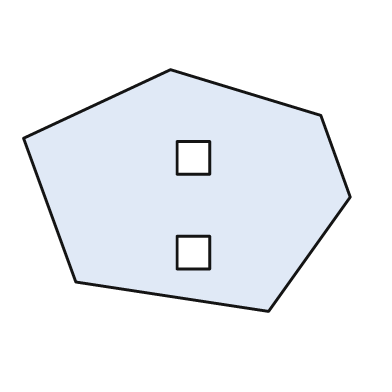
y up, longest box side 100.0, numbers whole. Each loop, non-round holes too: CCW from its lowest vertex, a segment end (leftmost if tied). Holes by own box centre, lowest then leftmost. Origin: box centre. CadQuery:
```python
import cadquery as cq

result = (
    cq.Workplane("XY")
    .moveTo(25.0, -37.0)
    .lineTo(50.0, -2.0)
    .lineTo(41.0, 23.0)
    .lineTo(-5.0, 37.0)
    .lineTo(-50.0, 16.0)
    .lineTo(-34.0, -28.0)
    .close()
    .moveTo(-3.0, -24.0)
    .lineTo(7.0, -24.0)
    .lineTo(7.0, -14.0)
    .lineTo(-3.0, -14.0)
    .close()
    .moveTo(-3.0, 5.0)
    .lineTo(7.0, 5.0)
    .lineTo(7.0, 15.0)
    .lineTo(-3.0, 15.0)
    .close()
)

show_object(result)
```